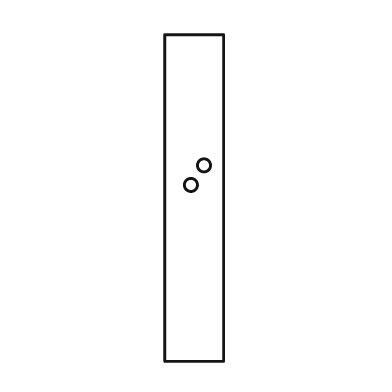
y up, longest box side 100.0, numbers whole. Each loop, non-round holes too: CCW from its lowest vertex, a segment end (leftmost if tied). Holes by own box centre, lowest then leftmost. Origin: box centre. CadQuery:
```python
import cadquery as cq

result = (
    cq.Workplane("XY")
    .moveTo(-9.0, -50.0)
    .lineTo(9.0, -50.0)
    .lineTo(9.0, 50.0)
    .lineTo(-9.0, 50.0)
    .close()
    .moveTo(-1.0, 4.0)
    .circle(2.0)
    .moveTo(3.0, 10.0)
    .circle(2.0)
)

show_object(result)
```